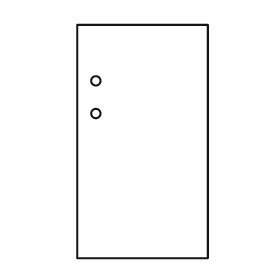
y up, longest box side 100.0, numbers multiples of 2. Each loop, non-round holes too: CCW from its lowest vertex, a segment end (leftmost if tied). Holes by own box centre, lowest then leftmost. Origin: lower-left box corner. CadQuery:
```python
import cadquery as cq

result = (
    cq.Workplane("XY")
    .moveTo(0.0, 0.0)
    .lineTo(56.0, 0.0)
    .lineTo(56.0, 100.0)
    .lineTo(0.0, 100.0)
    .close()
    .moveTo(8.0, 62.0)
    .circle(2.0)
    .moveTo(8.0, 76.0)
    .circle(2.0)
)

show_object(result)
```